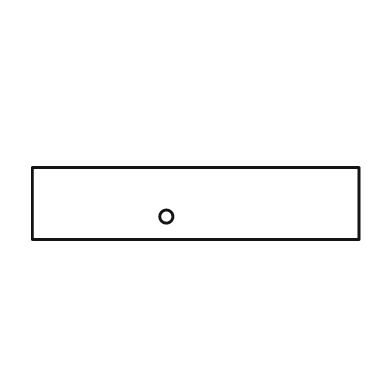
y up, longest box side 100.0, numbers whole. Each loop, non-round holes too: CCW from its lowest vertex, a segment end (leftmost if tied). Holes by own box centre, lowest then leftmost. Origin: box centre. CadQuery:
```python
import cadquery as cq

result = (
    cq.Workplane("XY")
    .moveTo(-50.0, -11.0)
    .lineTo(50.0, -11.0)
    .lineTo(50.0, 11.0)
    .lineTo(-50.0, 11.0)
    .close()
    .moveTo(-9.0, -4.0)
    .circle(2.0)
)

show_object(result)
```